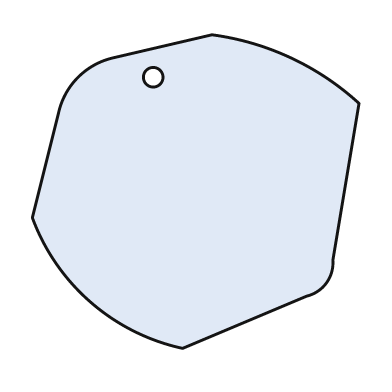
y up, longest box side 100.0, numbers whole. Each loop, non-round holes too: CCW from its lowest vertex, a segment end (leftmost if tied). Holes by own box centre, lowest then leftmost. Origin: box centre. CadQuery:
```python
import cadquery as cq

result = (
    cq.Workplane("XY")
    .moveTo(-4.0, -48.0)
    .lineTo(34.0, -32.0)
    .threePointArc((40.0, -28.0), (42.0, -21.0))
    .lineTo(50.0, 27.0)
    .threePointArc((29.0, 41.0), (5.0, 48.0))
    .lineTo(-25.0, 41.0)
    .threePointArc((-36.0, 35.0), (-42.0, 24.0))
    .lineTo(-50.0, -8.0)
    .threePointArc((-32.0, -34.0), (-4.0, -48.0))
    .close()
    .moveTo(-13.0, 35.0)
    .circle(3.0)
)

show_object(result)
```